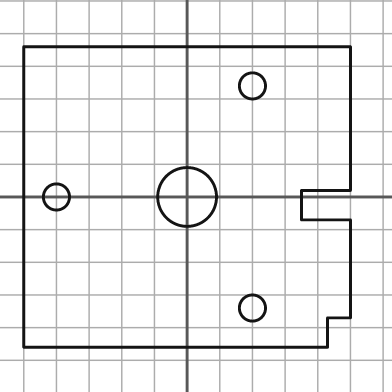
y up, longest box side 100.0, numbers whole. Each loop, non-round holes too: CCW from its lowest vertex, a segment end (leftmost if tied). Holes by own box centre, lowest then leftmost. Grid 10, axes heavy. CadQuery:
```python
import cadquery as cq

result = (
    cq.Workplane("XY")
    .moveTo(-50.0, -46.0)
    .lineTo(43.0, -46.0)
    .lineTo(43.0, -37.0)
    .lineTo(50.0, -37.0)
    .lineTo(50.0, -7.0)
    .lineTo(35.0, -7.0)
    .lineTo(35.0, 2.0)
    .lineTo(50.0, 2.0)
    .lineTo(50.0, 46.0)
    .lineTo(-50.0, 46.0)
    .close()
    .moveTo(20.0, -34.0)
    .circle(4.0)
    .moveTo(-40.0, 0.0)
    .circle(4.0)
    .moveTo(0.0, 0.0)
    .circle(9.0)
    .moveTo(20.0, 34.0)
    .circle(4.0)
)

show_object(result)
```